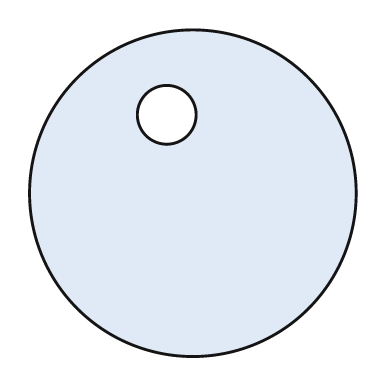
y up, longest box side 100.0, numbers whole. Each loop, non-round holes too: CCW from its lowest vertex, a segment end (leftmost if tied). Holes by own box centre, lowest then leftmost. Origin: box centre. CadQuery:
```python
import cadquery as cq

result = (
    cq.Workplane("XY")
    .moveTo(0.0, 0.0)
    .circle(50.0)
    .moveTo(-8.0, 24.0)
    .circle(9.0)
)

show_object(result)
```